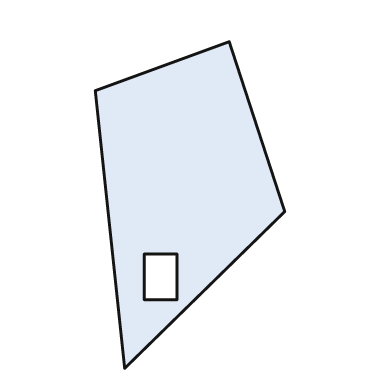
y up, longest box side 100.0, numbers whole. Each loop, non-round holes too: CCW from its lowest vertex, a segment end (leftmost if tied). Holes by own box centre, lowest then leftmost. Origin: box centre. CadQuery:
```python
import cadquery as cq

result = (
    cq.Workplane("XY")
    .moveTo(-20.0, -50.0)
    .lineTo(29.0, -2.0)
    .lineTo(12.0, 50.0)
    .lineTo(-29.0, 35.0)
    .close()
    .moveTo(-14.0, -29.0)
    .lineTo(-4.0, -29.0)
    .lineTo(-4.0, -15.0)
    .lineTo(-14.0, -15.0)
    .close()
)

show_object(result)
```